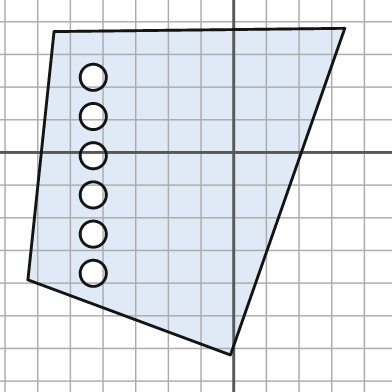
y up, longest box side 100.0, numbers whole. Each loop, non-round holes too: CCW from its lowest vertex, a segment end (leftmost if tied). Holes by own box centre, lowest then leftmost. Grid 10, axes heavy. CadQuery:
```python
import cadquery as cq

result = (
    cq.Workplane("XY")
    .moveTo(-1.0, -62.0)
    .lineTo(34.0, 38.0)
    .lineTo(-55.0, 37.0)
    .lineTo(-63.0, -39.0)
    .close()
    .moveTo(-43.0, -37.0)
    .circle(4.0)
    .moveTo(-43.0, -25.0)
    .circle(4.0)
    .moveTo(-43.0, -13.0)
    .circle(4.0)
    .moveTo(-43.0, -1.0)
    .circle(4.0)
    .moveTo(-43.0, 11.0)
    .circle(4.0)
    .moveTo(-43.0, 23.0)
    .circle(4.0)
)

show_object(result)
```